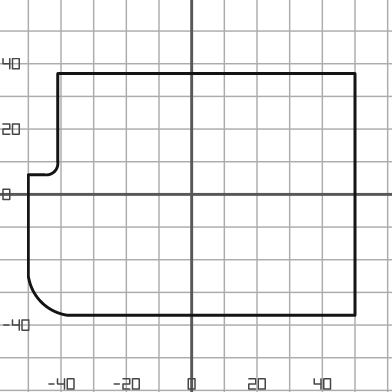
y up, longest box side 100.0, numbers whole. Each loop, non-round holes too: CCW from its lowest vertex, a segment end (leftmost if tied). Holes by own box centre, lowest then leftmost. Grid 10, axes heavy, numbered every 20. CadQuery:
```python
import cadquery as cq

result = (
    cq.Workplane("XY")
    .moveTo(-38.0, -37.0)
    .lineTo(50.0, -37.0)
    .lineTo(50.0, 37.0)
    .lineTo(-41.0, 37.0)
    .lineTo(-41.0, 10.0)
    .threePointArc((-42.0, 7.0), (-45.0, 6.0))
    .lineTo(-50.0, 6.0)
    .lineTo(-50.0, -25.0)
    .threePointArc((-46.0, -33.0), (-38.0, -37.0))
    .close()
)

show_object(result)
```